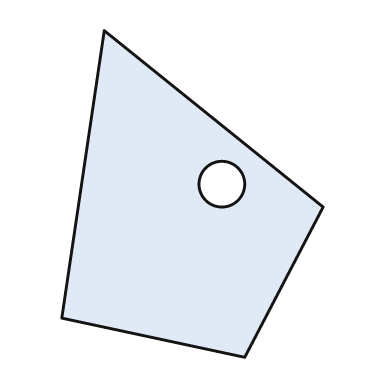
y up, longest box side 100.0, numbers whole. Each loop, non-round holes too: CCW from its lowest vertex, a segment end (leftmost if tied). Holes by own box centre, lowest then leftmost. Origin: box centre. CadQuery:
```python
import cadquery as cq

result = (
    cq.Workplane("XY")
    .moveTo(16.0, -50.0)
    .lineTo(40.0, -4.0)
    .lineTo(-27.0, 50.0)
    .lineTo(-40.0, -38.0)
    .close()
    .moveTo(9.0, 3.0)
    .circle(7.0)
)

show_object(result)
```